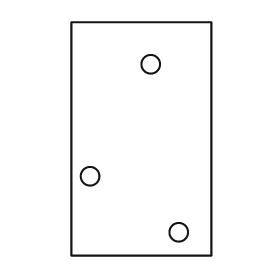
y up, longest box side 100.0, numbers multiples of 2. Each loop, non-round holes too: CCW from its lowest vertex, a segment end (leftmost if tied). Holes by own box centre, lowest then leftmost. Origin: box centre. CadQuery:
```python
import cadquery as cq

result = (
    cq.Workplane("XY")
    .moveTo(-30.0, -50.0)
    .lineTo(30.0, -50.0)
    .lineTo(30.0, 50.0)
    .lineTo(-30.0, 50.0)
    .close()
    .moveTo(16.0, -40.0)
    .circle(4.0)
    .moveTo(-22.0, -16.0)
    .circle(4.0)
    .moveTo(4.0, 32.0)
    .circle(4.0)
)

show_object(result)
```